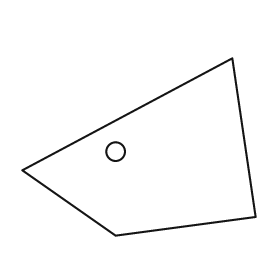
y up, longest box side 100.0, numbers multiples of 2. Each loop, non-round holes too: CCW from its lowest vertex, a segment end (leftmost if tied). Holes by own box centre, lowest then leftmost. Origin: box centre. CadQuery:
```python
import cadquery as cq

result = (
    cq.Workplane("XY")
    .moveTo(-10.0, -38.0)
    .lineTo(50.0, -30.0)
    .lineTo(40.0, 38.0)
    .lineTo(-50.0, -10.0)
    .close()
    .moveTo(-10.0, -2.0)
    .circle(4.0)
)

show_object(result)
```